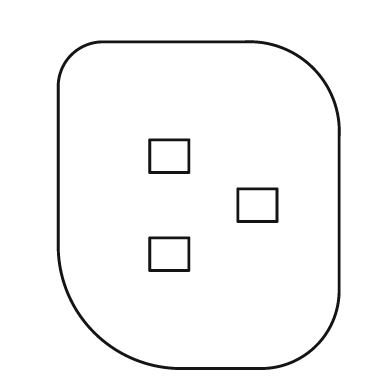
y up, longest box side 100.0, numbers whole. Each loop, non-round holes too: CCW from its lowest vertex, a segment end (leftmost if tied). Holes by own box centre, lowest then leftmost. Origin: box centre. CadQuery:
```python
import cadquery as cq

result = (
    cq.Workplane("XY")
    .moveTo(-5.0, -50.0)
    .lineTo(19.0, -50.0)
    .threePointArc((36.0, -43.0), (43.0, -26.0))
    .lineTo(43.0, 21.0)
    .threePointArc((35.0, 42.0), (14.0, 50.0))
    .lineTo(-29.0, 50.0)
    .threePointArc((-39.0, 46.0), (-43.0, 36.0))
    .lineTo(-43.0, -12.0)
    .threePointArc((-32.0, -39.0), (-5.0, -50.0))
    .close()
    .moveTo(-15.0, -20.0)
    .lineTo(-3.0, -20.0)
    .lineTo(-3.0, -10.0)
    .lineTo(-15.0, -10.0)
    .close()
    .moveTo(12.0, -5.0)
    .lineTo(24.0, -5.0)
    .lineTo(24.0, 5.0)
    .lineTo(12.0, 5.0)
    .close()
    .moveTo(-15.0, 10.0)
    .lineTo(-3.0, 10.0)
    .lineTo(-3.0, 20.0)
    .lineTo(-15.0, 20.0)
    .close()
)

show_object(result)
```